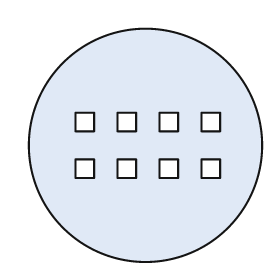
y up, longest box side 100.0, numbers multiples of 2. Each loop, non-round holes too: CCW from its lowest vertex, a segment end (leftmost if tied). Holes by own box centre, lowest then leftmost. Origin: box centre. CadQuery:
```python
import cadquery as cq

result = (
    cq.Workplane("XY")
    .moveTo(0.0, 0.0)
    .circle(50.0)
    .moveTo(-30.0, -14.0)
    .lineTo(-22.0, -14.0)
    .lineTo(-22.0, -6.0)
    .lineTo(-30.0, -6.0)
    .close()
    .moveTo(-12.0, -14.0)
    .lineTo(-4.0, -14.0)
    .lineTo(-4.0, -6.0)
    .lineTo(-12.0, -6.0)
    .close()
    .moveTo(6.0, -14.0)
    .lineTo(14.0, -14.0)
    .lineTo(14.0, -6.0)
    .lineTo(6.0, -6.0)
    .close()
    .moveTo(24.0, -14.0)
    .lineTo(32.0, -14.0)
    .lineTo(32.0, -6.0)
    .lineTo(24.0, -6.0)
    .close()
    .moveTo(-30.0, 6.0)
    .lineTo(-22.0, 6.0)
    .lineTo(-22.0, 14.0)
    .lineTo(-30.0, 14.0)
    .close()
    .moveTo(-12.0, 6.0)
    .lineTo(-4.0, 6.0)
    .lineTo(-4.0, 14.0)
    .lineTo(-12.0, 14.0)
    .close()
    .moveTo(6.0, 6.0)
    .lineTo(14.0, 6.0)
    .lineTo(14.0, 14.0)
    .lineTo(6.0, 14.0)
    .close()
    .moveTo(24.0, 6.0)
    .lineTo(32.0, 6.0)
    .lineTo(32.0, 14.0)
    .lineTo(24.0, 14.0)
    .close()
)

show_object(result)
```